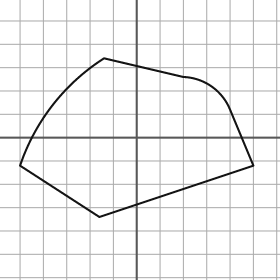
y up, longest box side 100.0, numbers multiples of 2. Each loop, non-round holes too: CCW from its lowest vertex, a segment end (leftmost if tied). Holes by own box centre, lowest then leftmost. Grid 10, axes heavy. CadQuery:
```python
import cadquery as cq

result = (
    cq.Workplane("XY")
    .moveTo(-16.0, -34.0)
    .lineTo(50.0, -12.0)
    .lineTo(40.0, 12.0)
    .threePointArc((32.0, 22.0), (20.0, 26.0))
    .lineTo(-14.0, 34.0)
    .threePointArc((-36.0, 14.0), (-50.0, -12.0))
    .close()
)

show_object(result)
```